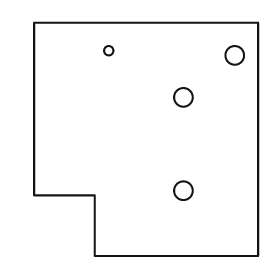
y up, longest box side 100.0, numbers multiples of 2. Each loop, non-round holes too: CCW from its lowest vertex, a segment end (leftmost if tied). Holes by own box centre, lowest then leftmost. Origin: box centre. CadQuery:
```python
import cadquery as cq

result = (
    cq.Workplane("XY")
    .moveTo(-22.0, -50.0)
    .lineTo(48.0, -50.0)
    .lineTo(48.0, 50.0)
    .lineTo(-48.0, 50.0)
    .lineTo(-48.0, -24.0)
    .lineTo(-22.0, -24.0)
    .close()
    .moveTo(16.0, -22.0)
    .circle(4.0)
    .moveTo(16.0, 18.0)
    .circle(4.0)
    .moveTo(38.0, 36.0)
    .circle(4.0)
    .moveTo(-16.0, 38.0)
    .circle(2.0)
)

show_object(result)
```